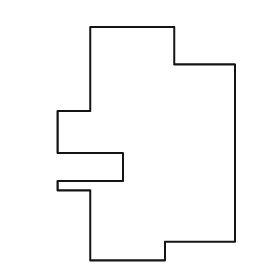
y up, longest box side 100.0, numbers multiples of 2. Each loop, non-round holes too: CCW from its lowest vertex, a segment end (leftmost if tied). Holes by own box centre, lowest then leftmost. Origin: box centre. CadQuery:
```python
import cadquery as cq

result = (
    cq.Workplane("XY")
    .moveTo(-24.0, -50.0)
    .lineTo(8.0, -50.0)
    .lineTo(8.0, -42.0)
    .lineTo(38.0, -42.0)
    .lineTo(38.0, 34.0)
    .lineTo(12.0, 34.0)
    .lineTo(12.0, 50.0)
    .lineTo(-24.0, 50.0)
    .lineTo(-24.0, 14.0)
    .lineTo(-38.0, 14.0)
    .lineTo(-38.0, -4.0)
    .lineTo(-10.0, -4.0)
    .lineTo(-10.0, -16.0)
    .lineTo(-38.0, -16.0)
    .lineTo(-38.0, -20.0)
    .lineTo(-24.0, -20.0)
    .close()
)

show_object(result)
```